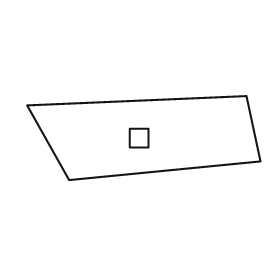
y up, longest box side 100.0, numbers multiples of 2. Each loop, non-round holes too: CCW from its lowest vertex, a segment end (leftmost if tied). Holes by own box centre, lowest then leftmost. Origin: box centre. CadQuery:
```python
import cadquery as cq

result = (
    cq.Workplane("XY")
    .moveTo(-32.0, -18.0)
    .lineTo(50.0, -10.0)
    .lineTo(44.0, 18.0)
    .lineTo(-50.0, 14.0)
    .close()
    .moveTo(-6.0, -4.0)
    .lineTo(2.0, -4.0)
    .lineTo(2.0, 4.0)
    .lineTo(-6.0, 4.0)
    .close()
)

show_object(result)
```